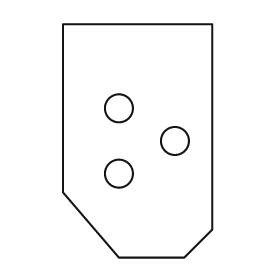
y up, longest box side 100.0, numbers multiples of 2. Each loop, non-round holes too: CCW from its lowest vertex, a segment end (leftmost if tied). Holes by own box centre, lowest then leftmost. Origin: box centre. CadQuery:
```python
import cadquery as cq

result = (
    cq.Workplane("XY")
    .moveTo(-8.0, -50.0)
    .lineTo(20.0, -50.0)
    .lineTo(32.0, -38.0)
    .lineTo(32.0, 50.0)
    .lineTo(-32.0, 50.0)
    .lineTo(-32.0, -22.0)
    .close()
    .moveTo(-8.0, -14.0)
    .circle(6.0)
    .moveTo(16.0, 0.0)
    .circle(6.0)
    .moveTo(-8.0, 14.0)
    .circle(6.0)
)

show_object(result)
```